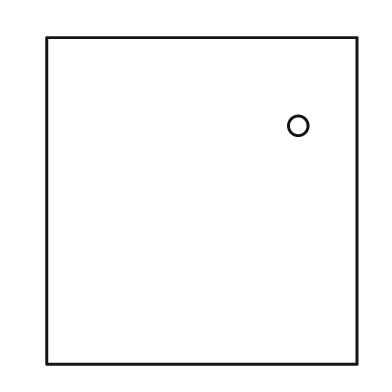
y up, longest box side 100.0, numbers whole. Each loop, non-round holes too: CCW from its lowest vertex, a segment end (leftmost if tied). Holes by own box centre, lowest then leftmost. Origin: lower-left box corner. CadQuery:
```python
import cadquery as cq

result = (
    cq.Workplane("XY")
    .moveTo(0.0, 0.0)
    .lineTo(95.0, 0.0)
    .lineTo(95.0, 100.0)
    .lineTo(0.0, 100.0)
    .close()
    .moveTo(77.0, 73.0)
    .circle(3.0)
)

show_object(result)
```